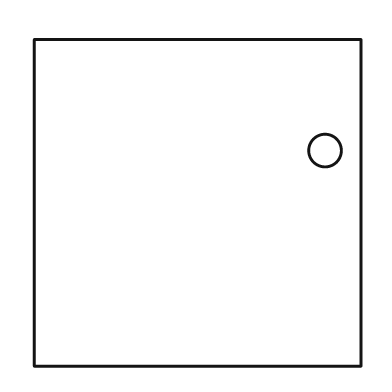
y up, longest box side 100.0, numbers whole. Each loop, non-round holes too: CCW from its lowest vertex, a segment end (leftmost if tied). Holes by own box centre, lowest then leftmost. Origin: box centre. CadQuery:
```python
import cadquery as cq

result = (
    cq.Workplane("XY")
    .moveTo(-50.0, -50.0)
    .lineTo(50.0, -50.0)
    .lineTo(50.0, 50.0)
    .lineTo(-50.0, 50.0)
    .close()
    .moveTo(39.0, 16.0)
    .circle(5.0)
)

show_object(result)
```